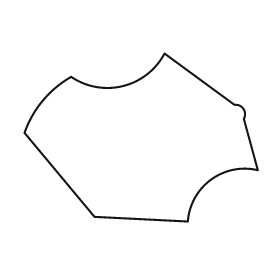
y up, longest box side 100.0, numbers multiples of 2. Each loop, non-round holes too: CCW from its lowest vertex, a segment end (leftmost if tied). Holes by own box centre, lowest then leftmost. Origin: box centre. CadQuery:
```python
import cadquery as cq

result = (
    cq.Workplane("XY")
    .moveTo(20.0, -36.0)
    .threePointArc((30.0, -18.0), (50.0, -14.0))
    .lineTo(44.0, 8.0)
    .threePointArc((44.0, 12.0), (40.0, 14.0))
    .lineTo(10.0, 36.0)
    .threePointArc((-8.0, 22.0), (-30.0, 26.0))
    .threePointArc((-42.0, 16.0), (-50.0, 2.0))
    .lineTo(-20.0, -34.0)
    .close()
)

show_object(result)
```